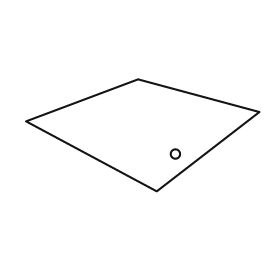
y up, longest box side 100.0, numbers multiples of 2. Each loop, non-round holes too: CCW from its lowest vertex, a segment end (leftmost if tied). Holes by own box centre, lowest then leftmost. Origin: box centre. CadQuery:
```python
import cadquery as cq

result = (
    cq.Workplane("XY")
    .moveTo(6.0, -24.0)
    .lineTo(50.0, 10.0)
    .lineTo(-2.0, 24.0)
    .lineTo(-50.0, 6.0)
    .close()
    .moveTo(14.0, -8.0)
    .circle(2.0)
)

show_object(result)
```